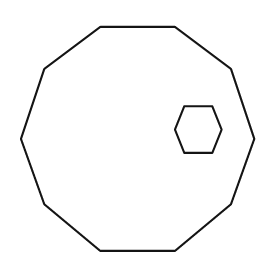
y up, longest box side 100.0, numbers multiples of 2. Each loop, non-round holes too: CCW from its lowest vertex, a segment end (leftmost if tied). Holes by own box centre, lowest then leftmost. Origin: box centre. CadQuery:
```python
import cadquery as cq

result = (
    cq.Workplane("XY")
    .moveTo(-16.0, -48.0)
    .lineTo(16.0, -48.0)
    .lineTo(40.0, -28.0)
    .lineTo(50.0, 0.0)
    .lineTo(40.0, 30.0)
    .lineTo(16.0, 48.0)
    .lineTo(-16.0, 48.0)
    .lineTo(-40.0, 30.0)
    .lineTo(-50.0, 0.0)
    .lineTo(-40.0, -28.0)
    .close()
    .moveTo(20.0, -6.0)
    .lineTo(32.0, -6.0)
    .lineTo(36.0, 4.0)
    .lineTo(32.0, 14.0)
    .lineTo(20.0, 14.0)
    .lineTo(16.0, 4.0)
    .close()
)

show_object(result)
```